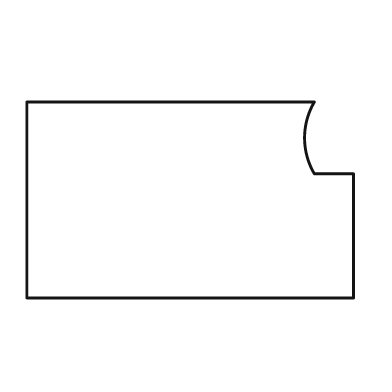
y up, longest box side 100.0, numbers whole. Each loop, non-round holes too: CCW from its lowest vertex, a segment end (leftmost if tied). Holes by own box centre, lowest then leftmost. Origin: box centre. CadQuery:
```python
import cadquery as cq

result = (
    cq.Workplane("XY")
    .moveTo(-50.0, -30.0)
    .lineTo(50.0, -30.0)
    .lineTo(50.0, 8.0)
    .lineTo(38.0, 8.0)
    .threePointArc((35.0, 19.0), (38.0, 30.0))
    .lineTo(-50.0, 30.0)
    .close()
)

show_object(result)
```